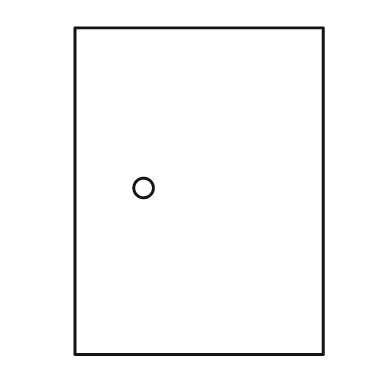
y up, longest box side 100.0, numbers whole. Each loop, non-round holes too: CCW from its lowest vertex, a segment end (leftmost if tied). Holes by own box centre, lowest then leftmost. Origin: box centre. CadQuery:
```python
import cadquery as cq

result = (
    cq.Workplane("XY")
    .moveTo(-38.0, -50.0)
    .lineTo(38.0, -50.0)
    .lineTo(38.0, 50.0)
    .lineTo(-38.0, 50.0)
    .close()
    .moveTo(-17.0, 1.0)
    .circle(3.0)
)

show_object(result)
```